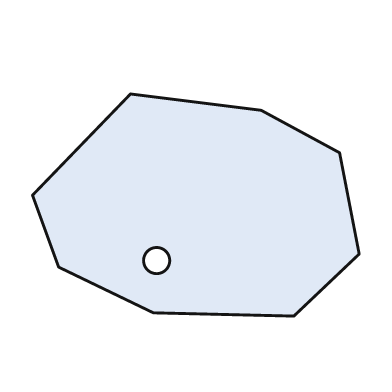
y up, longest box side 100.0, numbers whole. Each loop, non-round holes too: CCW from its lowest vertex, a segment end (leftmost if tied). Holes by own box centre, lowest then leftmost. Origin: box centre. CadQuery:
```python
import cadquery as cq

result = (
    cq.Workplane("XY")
    .moveTo(30.0, -34.0)
    .lineTo(50.0, -15.0)
    .lineTo(44.0, 16.0)
    .lineTo(20.0, 29.0)
    .lineTo(-20.0, 34.0)
    .lineTo(-50.0, 3.0)
    .lineTo(-42.0, -19.0)
    .lineTo(-13.0, -33.0)
    .close()
    .moveTo(-12.0, -17.0)
    .circle(4.0)
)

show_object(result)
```